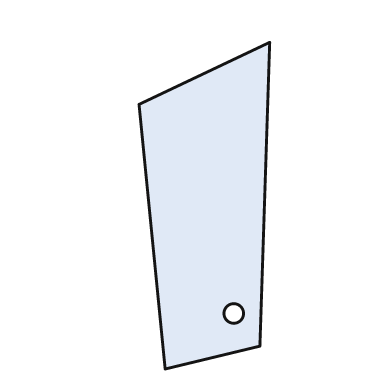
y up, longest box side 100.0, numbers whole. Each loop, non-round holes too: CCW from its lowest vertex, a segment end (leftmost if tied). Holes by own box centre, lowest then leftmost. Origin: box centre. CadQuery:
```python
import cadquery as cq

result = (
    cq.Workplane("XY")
    .moveTo(-12.0, -50.0)
    .lineTo(17.0, -43.0)
    .lineTo(20.0, 50.0)
    .lineTo(-20.0, 31.0)
    .close()
    .moveTo(9.0, -33.0)
    .circle(3.0)
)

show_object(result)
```